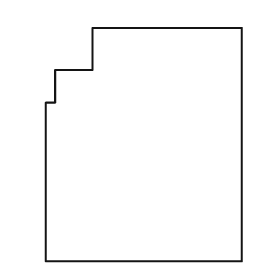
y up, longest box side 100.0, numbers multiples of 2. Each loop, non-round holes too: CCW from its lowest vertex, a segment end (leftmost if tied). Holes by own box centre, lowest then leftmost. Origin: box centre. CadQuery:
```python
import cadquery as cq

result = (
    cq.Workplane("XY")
    .moveTo(-42.0, -50.0)
    .lineTo(42.0, -50.0)
    .lineTo(42.0, 50.0)
    .lineTo(-22.0, 50.0)
    .lineTo(-22.0, 32.0)
    .lineTo(-38.0, 32.0)
    .lineTo(-38.0, 18.0)
    .lineTo(-42.0, 18.0)
    .close()
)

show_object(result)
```